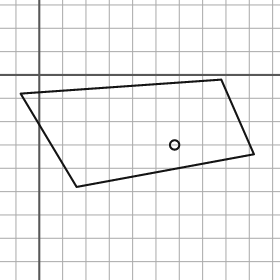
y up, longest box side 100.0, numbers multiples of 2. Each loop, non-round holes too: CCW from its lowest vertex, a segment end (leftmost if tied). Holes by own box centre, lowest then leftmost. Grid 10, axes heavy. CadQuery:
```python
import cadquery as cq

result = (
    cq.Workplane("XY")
    .moveTo(16.0, -48.0)
    .lineTo(92.0, -34.0)
    .lineTo(78.0, -2.0)
    .lineTo(-8.0, -8.0)
    .close()
    .moveTo(58.0, -30.0)
    .circle(2.0)
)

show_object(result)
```